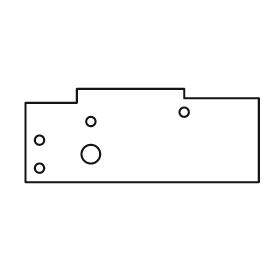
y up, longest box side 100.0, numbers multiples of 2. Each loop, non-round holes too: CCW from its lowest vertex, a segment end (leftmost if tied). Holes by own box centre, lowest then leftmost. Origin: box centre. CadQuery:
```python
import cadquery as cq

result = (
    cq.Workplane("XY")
    .moveTo(-50.0, -20.0)
    .lineTo(50.0, -20.0)
    .lineTo(50.0, 16.0)
    .lineTo(18.0, 16.0)
    .lineTo(18.0, 20.0)
    .lineTo(-28.0, 20.0)
    .lineTo(-28.0, 14.0)
    .lineTo(-50.0, 14.0)
    .close()
    .moveTo(-44.0, -14.0)
    .circle(2.0)
    .moveTo(-22.0, -8.0)
    .circle(4.0)
    .moveTo(-44.0, -2.0)
    .circle(2.0)
    .moveTo(-22.0, 6.0)
    .circle(2.0)
    .moveTo(18.0, 10.0)
    .circle(2.0)
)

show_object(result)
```